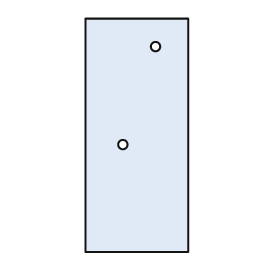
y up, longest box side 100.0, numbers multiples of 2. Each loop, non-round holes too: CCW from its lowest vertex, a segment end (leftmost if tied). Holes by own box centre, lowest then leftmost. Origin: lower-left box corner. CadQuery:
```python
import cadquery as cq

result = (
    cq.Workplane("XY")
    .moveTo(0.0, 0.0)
    .lineTo(44.0, 0.0)
    .lineTo(44.0, 100.0)
    .lineTo(0.0, 100.0)
    .close()
    .moveTo(16.0, 46.0)
    .circle(2.0)
    .moveTo(30.0, 88.0)
    .circle(2.0)
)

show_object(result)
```